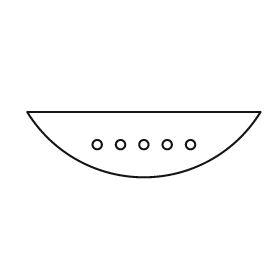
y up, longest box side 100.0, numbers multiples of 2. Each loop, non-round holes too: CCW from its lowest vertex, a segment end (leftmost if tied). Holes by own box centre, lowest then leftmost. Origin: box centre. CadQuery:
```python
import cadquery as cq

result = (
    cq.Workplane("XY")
    .moveTo(-50.0, 14.0)
    .threePointArc((0.0, -14.0), (50.0, 14.0))
    .close()
    .moveTo(-20.0, 0.0)
    .circle(2.0)
    .moveTo(-10.0, 0.0)
    .circle(2.0)
    .moveTo(0.0, 0.0)
    .circle(2.0)
    .moveTo(10.0, 0.0)
    .circle(2.0)
    .moveTo(20.0, 0.0)
    .circle(2.0)
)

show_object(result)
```